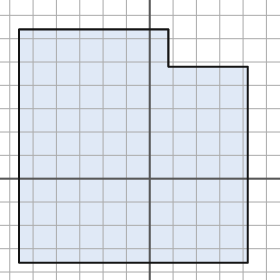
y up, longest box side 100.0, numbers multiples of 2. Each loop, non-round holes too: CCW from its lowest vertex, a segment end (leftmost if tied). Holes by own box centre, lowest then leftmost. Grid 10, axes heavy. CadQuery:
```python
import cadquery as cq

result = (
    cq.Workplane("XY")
    .moveTo(-56.0, -36.0)
    .lineTo(42.0, -36.0)
    .lineTo(42.0, 48.0)
    .lineTo(8.0, 48.0)
    .lineTo(8.0, 64.0)
    .lineTo(-56.0, 64.0)
    .close()
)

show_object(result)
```